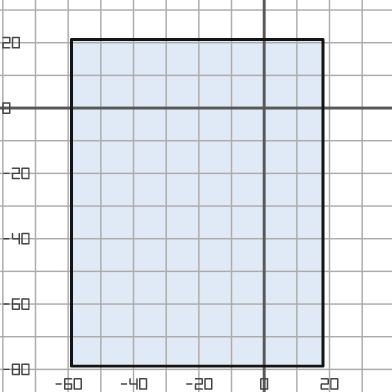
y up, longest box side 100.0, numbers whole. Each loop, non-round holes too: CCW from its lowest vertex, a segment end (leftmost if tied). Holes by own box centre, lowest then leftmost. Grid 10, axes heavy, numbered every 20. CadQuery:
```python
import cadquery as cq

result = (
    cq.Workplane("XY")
    .moveTo(-59.0, -79.0)
    .lineTo(18.0, -79.0)
    .lineTo(18.0, 21.0)
    .lineTo(-59.0, 21.0)
    .close()
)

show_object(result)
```